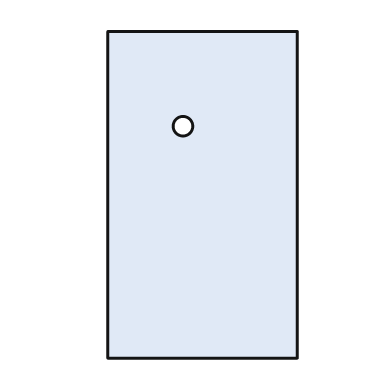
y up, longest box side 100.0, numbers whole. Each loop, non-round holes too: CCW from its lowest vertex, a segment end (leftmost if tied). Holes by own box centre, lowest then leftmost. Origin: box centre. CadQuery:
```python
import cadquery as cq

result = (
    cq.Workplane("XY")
    .moveTo(-29.0, -50.0)
    .lineTo(29.0, -50.0)
    .lineTo(29.0, 50.0)
    .lineTo(-29.0, 50.0)
    .close()
    .moveTo(-6.0, 21.0)
    .circle(3.0)
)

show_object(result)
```